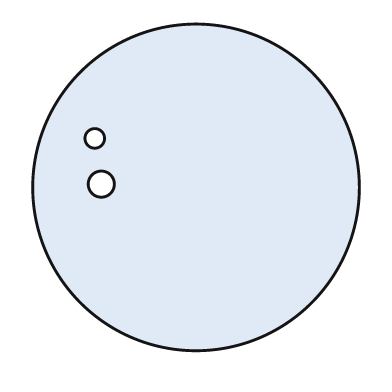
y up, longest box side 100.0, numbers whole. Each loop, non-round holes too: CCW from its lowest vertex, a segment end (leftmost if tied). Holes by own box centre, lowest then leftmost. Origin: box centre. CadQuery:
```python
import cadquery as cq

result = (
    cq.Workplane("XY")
    .moveTo(0.0, 0.0)
    .circle(50.0)
    .moveTo(-29.0, 1.0)
    .circle(4.0)
    .moveTo(-31.0, 15.0)
    .circle(3.0)
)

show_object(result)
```